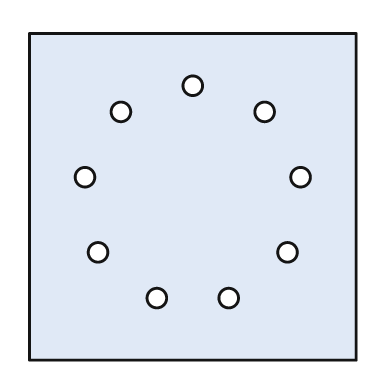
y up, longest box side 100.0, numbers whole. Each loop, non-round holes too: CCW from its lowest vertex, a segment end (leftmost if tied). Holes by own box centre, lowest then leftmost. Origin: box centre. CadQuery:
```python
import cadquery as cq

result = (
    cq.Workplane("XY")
    .moveTo(-50.0, -50.0)
    .lineTo(50.0, -50.0)
    .lineTo(50.0, 50.0)
    .lineTo(-50.0, 50.0)
    .close()
    .moveTo(-11.0, -31.0)
    .circle(3.0)
    .moveTo(11.0, -31.0)
    .circle(3.0)
    .moveTo(-29.0, -17.0)
    .circle(3.0)
    .moveTo(29.0, -17.0)
    .circle(3.0)
    .moveTo(-33.0, 6.0)
    .circle(3.0)
    .moveTo(33.0, 6.0)
    .circle(3.0)
    .moveTo(-22.0, 26.0)
    .circle(3.0)
    .moveTo(22.0, 26.0)
    .circle(3.0)
    .moveTo(0.0, 34.0)
    .circle(3.0)
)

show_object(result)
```